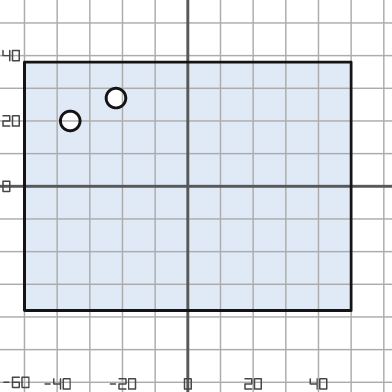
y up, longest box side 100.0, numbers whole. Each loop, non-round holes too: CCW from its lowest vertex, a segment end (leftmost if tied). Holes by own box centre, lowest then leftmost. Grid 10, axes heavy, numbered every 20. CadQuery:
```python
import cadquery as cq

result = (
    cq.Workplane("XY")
    .moveTo(-50.0, -38.0)
    .lineTo(50.0, -38.0)
    .lineTo(50.0, 38.0)
    .lineTo(-50.0, 38.0)
    .close()
    .moveTo(-36.0, 20.0)
    .circle(3.0)
    .moveTo(-22.0, 27.0)
    .circle(3.0)
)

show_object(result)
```